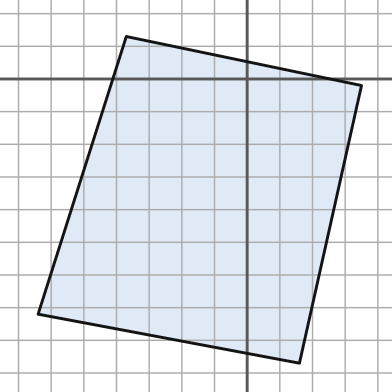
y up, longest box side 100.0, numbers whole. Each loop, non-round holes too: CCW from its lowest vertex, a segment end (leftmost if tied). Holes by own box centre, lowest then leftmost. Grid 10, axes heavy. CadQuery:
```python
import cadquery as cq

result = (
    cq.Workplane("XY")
    .moveTo(16.0, -87.0)
    .lineTo(35.0, -2.0)
    .lineTo(-37.0, 13.0)
    .lineTo(-64.0, -72.0)
    .close()
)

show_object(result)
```